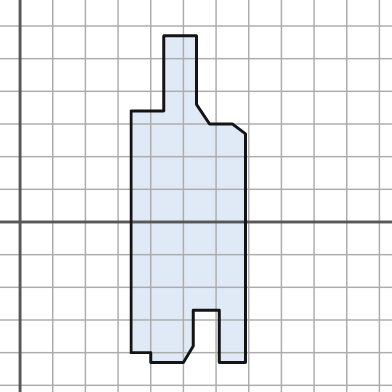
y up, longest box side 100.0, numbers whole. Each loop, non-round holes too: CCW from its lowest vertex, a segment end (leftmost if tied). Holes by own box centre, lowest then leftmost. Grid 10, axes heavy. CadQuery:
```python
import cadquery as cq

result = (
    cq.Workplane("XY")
    .moveTo(40.0, -43.0)
    .lineTo(50.0, -43.0)
    .lineTo(53.0, -38.0)
    .lineTo(53.0, -27.0)
    .lineTo(61.0, -27.0)
    .lineTo(61.0, -43.0)
    .lineTo(69.0, -43.0)
    .lineTo(69.0, 27.0)
    .lineTo(65.0, 30.0)
    .lineTo(58.0, 30.0)
    .lineTo(54.0, 36.0)
    .lineTo(54.0, 57.0)
    .lineTo(44.0, 57.0)
    .lineTo(44.0, 34.0)
    .lineTo(34.0, 34.0)
    .lineTo(34.0, -40.0)
    .lineTo(40.0, -40.0)
    .close()
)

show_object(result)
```